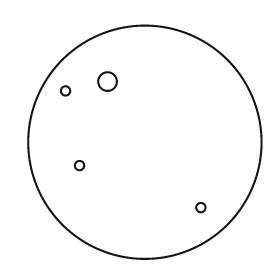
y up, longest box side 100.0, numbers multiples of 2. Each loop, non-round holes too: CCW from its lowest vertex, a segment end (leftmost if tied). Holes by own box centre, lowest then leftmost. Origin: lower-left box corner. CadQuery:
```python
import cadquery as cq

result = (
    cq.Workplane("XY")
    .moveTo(50.0, 50.0)
    .circle(50.0)
    .moveTo(74.0, 22.0)
    .circle(2.0)
    .moveTo(22.0, 40.0)
    .circle(2.0)
    .moveTo(16.0, 72.0)
    .circle(2.0)
    .moveTo(34.0, 76.0)
    .circle(4.0)
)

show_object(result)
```